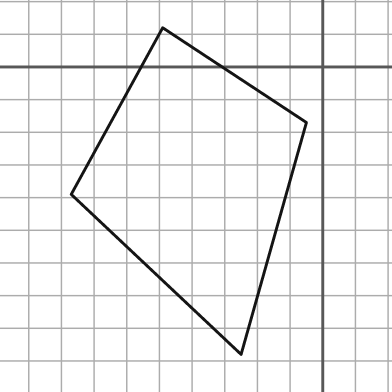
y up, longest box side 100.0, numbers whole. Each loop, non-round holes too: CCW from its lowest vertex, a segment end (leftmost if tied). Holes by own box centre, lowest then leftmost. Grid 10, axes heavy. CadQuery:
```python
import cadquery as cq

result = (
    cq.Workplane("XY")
    .moveTo(-25.0, -88.0)
    .lineTo(-5.0, -17.0)
    .lineTo(-49.0, 12.0)
    .lineTo(-77.0, -39.0)
    .close()
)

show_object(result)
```